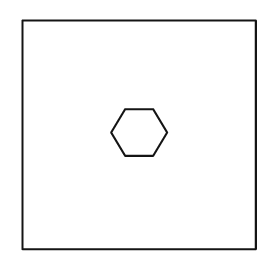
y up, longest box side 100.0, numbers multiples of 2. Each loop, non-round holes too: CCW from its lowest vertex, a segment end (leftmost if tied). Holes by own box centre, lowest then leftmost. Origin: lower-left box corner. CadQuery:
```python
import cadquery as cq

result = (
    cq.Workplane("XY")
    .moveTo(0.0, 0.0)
    .lineTo(100.0, 0.0)
    .lineTo(100.0, 98.0)
    .lineTo(0.0, 98.0)
    .close()
    .moveTo(44.0, 40.0)
    .lineTo(56.0, 40.0)
    .lineTo(62.0, 50.0)
    .lineTo(56.0, 60.0)
    .lineTo(44.0, 60.0)
    .lineTo(38.0, 50.0)
    .close()
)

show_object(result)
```